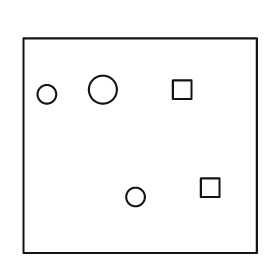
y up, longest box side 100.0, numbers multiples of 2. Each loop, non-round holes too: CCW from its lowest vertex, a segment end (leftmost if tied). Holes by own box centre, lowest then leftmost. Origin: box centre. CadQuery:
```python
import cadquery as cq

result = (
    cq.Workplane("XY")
    .moveTo(-50.0, -46.0)
    .lineTo(50.0, -46.0)
    .lineTo(50.0, 46.0)
    .lineTo(-50.0, 46.0)
    .close()
    .moveTo(-2.0, -22.0)
    .circle(4.0)
    .moveTo(26.0, -22.0)
    .lineTo(34.0, -22.0)
    .lineTo(34.0, -14.0)
    .lineTo(26.0, -14.0)
    .close()
    .moveTo(-40.0, 22.0)
    .circle(4.0)
    .moveTo(-16.0, 24.0)
    .circle(6.0)
    .moveTo(14.0, 20.0)
    .lineTo(22.0, 20.0)
    .lineTo(22.0, 28.0)
    .lineTo(14.0, 28.0)
    .close()
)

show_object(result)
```